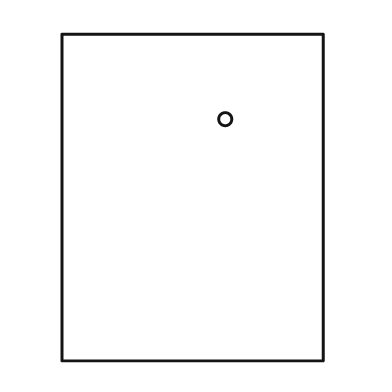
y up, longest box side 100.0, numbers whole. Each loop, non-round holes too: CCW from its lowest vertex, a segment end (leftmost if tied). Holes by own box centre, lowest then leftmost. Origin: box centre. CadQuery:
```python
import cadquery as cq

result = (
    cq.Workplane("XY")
    .moveTo(-40.0, -50.0)
    .lineTo(40.0, -50.0)
    .lineTo(40.0, 50.0)
    .lineTo(-40.0, 50.0)
    .close()
    .moveTo(10.0, 24.0)
    .circle(2.0)
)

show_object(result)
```